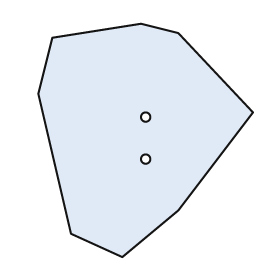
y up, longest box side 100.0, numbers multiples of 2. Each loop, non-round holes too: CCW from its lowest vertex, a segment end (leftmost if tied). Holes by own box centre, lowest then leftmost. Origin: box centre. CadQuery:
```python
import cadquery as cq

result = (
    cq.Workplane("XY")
    .moveTo(-10.0, -50.0)
    .lineTo(14.0, -30.0)
    .lineTo(46.0, 12.0)
    .lineTo(14.0, 46.0)
    .lineTo(-2.0, 50.0)
    .lineTo(-40.0, 44.0)
    .lineTo(-46.0, 20.0)
    .lineTo(-32.0, -40.0)
    .close()
    .moveTo(0.0, -8.0)
    .circle(2.0)
    .moveTo(0.0, 10.0)
    .circle(2.0)
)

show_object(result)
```